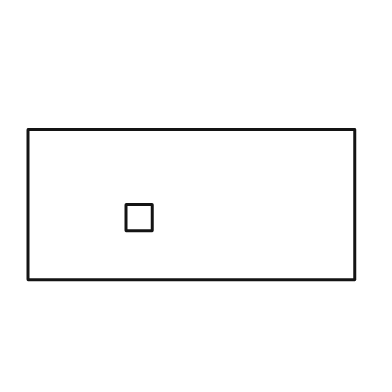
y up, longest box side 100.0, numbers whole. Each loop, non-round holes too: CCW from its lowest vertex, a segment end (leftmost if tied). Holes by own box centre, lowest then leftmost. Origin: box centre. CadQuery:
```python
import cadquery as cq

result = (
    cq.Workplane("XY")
    .moveTo(-50.0, -23.0)
    .lineTo(50.0, -23.0)
    .lineTo(50.0, 23.0)
    .lineTo(-50.0, 23.0)
    .close()
    .moveTo(-20.0, -8.0)
    .lineTo(-12.0, -8.0)
    .lineTo(-12.0, 0.0)
    .lineTo(-20.0, 0.0)
    .close()
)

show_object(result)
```